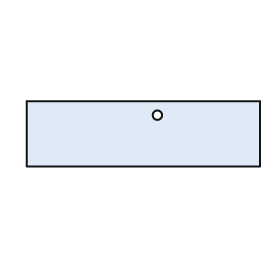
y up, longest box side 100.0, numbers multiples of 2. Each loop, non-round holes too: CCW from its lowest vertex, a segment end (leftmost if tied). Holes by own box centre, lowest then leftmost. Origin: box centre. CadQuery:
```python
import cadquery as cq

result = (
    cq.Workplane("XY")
    .moveTo(-50.0, -14.0)
    .lineTo(50.0, -14.0)
    .lineTo(50.0, 14.0)
    .lineTo(-50.0, 14.0)
    .close()
    .moveTo(6.0, 8.0)
    .circle(2.0)
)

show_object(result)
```